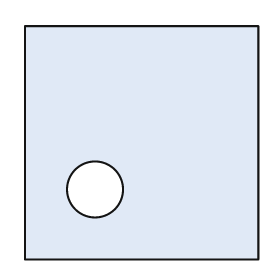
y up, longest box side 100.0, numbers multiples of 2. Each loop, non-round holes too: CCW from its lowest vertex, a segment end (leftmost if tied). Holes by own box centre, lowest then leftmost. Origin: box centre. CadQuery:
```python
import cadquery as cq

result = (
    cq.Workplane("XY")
    .moveTo(-50.0, -50.0)
    .lineTo(50.0, -50.0)
    .lineTo(50.0, 50.0)
    .lineTo(-50.0, 50.0)
    .close()
    .moveTo(-20.0, -20.0)
    .circle(12.0)
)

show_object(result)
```